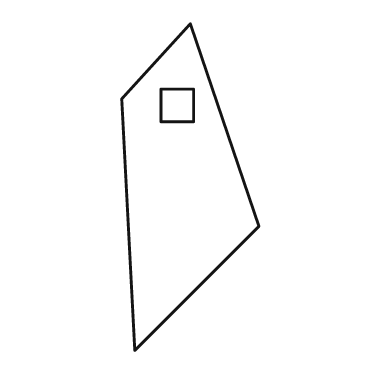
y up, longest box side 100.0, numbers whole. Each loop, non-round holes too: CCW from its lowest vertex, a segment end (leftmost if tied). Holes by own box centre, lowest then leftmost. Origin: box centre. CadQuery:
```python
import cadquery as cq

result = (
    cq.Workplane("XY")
    .moveTo(-17.0, -50.0)
    .lineTo(21.0, -12.0)
    .lineTo(0.0, 50.0)
    .lineTo(-21.0, 27.0)
    .close()
    .moveTo(-9.0, 20.0)
    .lineTo(1.0, 20.0)
    .lineTo(1.0, 30.0)
    .lineTo(-9.0, 30.0)
    .close()
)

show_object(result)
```